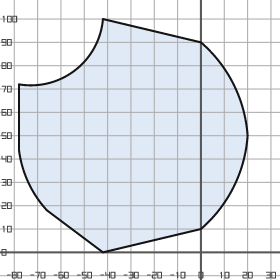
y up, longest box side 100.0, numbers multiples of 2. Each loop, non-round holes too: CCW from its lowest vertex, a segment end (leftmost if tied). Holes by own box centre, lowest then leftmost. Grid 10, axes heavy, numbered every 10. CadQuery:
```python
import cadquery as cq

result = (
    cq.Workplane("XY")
    .moveTo(-42.0, 0.0)
    .lineTo(0.0, 10.0)
    .threePointArc((14.0, 28.0), (20.0, 50.0))
    .threePointArc((14.0, 72.0), (0.0, 90.0))
    .lineTo(-42.0, 100.0)
    .threePointArc((-54.0, 78.0), (-78.0, 72.0))
    .lineTo(-78.0, 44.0)
    .threePointArc((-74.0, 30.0), (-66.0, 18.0))
    .close()
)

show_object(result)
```